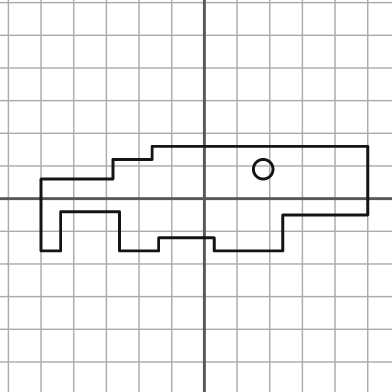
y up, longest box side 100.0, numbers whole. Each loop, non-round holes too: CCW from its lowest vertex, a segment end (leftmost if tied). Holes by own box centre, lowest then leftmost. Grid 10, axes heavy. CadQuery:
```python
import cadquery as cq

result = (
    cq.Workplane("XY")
    .moveTo(-50.0, -16.0)
    .lineTo(-44.0, -16.0)
    .lineTo(-44.0, -4.0)
    .lineTo(-26.0, -4.0)
    .lineTo(-26.0, -16.0)
    .lineTo(-14.0, -16.0)
    .lineTo(-14.0, -12.0)
    .lineTo(3.0, -12.0)
    .lineTo(3.0, -16.0)
    .lineTo(24.0, -16.0)
    .lineTo(24.0, -5.0)
    .lineTo(50.0, -5.0)
    .lineTo(50.0, 16.0)
    .lineTo(-16.0, 16.0)
    .lineTo(-16.0, 12.0)
    .lineTo(-28.0, 12.0)
    .lineTo(-28.0, 6.0)
    .lineTo(-50.0, 6.0)
    .close()
    .moveTo(18.0, 9.0)
    .circle(3.0)
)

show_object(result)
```